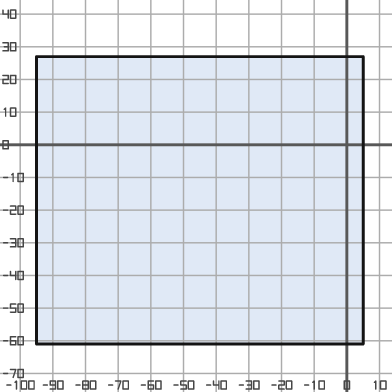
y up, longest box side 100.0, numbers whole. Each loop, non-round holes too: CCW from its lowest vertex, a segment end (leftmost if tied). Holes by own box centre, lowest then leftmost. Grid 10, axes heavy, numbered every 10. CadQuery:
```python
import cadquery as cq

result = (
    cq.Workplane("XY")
    .moveTo(-95.0, -61.0)
    .lineTo(5.0, -61.0)
    .lineTo(5.0, 27.0)
    .lineTo(-95.0, 27.0)
    .close()
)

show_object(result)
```